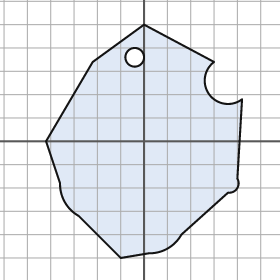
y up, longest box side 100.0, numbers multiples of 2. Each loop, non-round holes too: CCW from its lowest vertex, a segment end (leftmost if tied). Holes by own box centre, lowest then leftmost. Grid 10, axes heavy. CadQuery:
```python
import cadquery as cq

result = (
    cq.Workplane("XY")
    .moveTo(-10.0, -50.0)
    .lineTo(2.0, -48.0)
    .threePointArc((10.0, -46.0), (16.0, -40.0))
    .lineTo(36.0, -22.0)
    .threePointArc((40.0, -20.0), (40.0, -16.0))
    .lineTo(42.0, 18.0)
    .threePointArc((28.0, 20.0), (30.0, 34.0))
    .lineTo(0.0, 50.0)
    .lineTo(-22.0, 34.0)
    .lineTo(-42.0, 0.0)
    .lineTo(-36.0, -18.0)
    .threePointArc((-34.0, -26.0), (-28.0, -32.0))
    .close()
    .moveTo(-4.0, 36.0)
    .circle(4.0)
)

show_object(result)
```